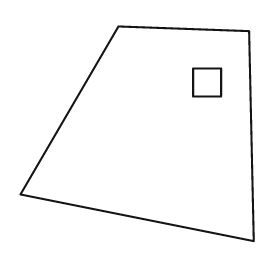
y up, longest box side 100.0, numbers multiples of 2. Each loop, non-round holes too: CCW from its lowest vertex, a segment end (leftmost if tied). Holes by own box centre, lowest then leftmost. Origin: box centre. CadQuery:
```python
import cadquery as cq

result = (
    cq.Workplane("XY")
    .moveTo(50.0, -46.0)
    .lineTo(48.0, 44.0)
    .lineTo(-8.0, 46.0)
    .lineTo(-50.0, -26.0)
    .close()
    .moveTo(24.0, 16.0)
    .lineTo(36.0, 16.0)
    .lineTo(36.0, 28.0)
    .lineTo(24.0, 28.0)
    .close()
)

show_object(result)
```